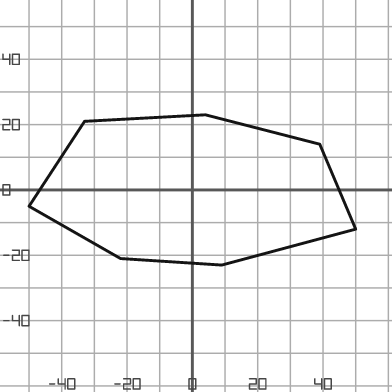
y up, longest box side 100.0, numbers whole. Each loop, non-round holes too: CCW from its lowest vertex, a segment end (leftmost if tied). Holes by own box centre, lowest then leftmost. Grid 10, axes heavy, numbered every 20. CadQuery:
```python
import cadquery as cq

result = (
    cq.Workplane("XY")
    .moveTo(9.0, -23.0)
    .lineTo(50.0, -12.0)
    .lineTo(39.0, 14.0)
    .lineTo(4.0, 23.0)
    .lineTo(-33.0, 21.0)
    .lineTo(-50.0, -5.0)
    .lineTo(-22.0, -21.0)
    .close()
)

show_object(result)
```